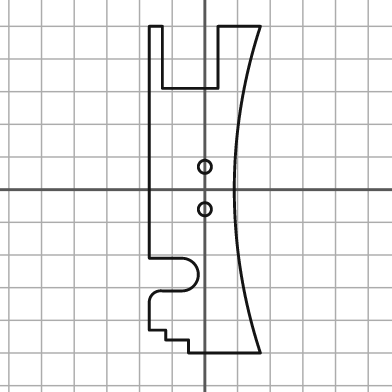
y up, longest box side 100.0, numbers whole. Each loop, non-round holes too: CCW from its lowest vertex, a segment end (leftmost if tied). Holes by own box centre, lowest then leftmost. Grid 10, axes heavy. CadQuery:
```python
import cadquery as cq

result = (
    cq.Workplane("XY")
    .moveTo(-5.0, -50.0)
    .lineTo(17.0, -50.0)
    .threePointArc((9.0, 0.0), (17.0, 50.0))
    .lineTo(4.0, 50.0)
    .lineTo(4.0, 31.0)
    .lineTo(-13.0, 31.0)
    .lineTo(-13.0, 50.0)
    .lineTo(-17.0, 50.0)
    .lineTo(-17.0, -21.0)
    .lineTo(-7.0, -21.0)
    .threePointArc((-2.0, -26.0), (-7.0, -31.0))
    .lineTo(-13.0, -31.0)
    .threePointArc((-16.0, -32.0), (-17.0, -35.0))
    .lineTo(-17.0, -43.0)
    .lineTo(-12.0, -43.0)
    .lineTo(-12.0, -46.0)
    .lineTo(-5.0, -46.0)
    .close()
    .moveTo(0.0, -6.0)
    .circle(2.0)
    .moveTo(0.0, 7.0)
    .circle(2.0)
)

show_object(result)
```